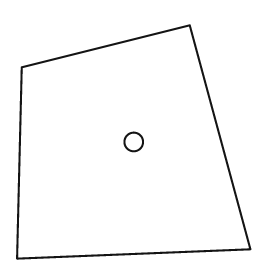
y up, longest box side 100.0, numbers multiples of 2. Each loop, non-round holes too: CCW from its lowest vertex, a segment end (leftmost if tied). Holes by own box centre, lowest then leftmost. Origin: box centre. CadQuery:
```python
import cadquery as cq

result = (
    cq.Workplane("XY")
    .moveTo(-50.0, -50.0)
    .lineTo(50.0, -46.0)
    .lineTo(24.0, 50.0)
    .lineTo(-48.0, 32.0)
    .close()
    .moveTo(0.0, 0.0)
    .circle(4.0)
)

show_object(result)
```